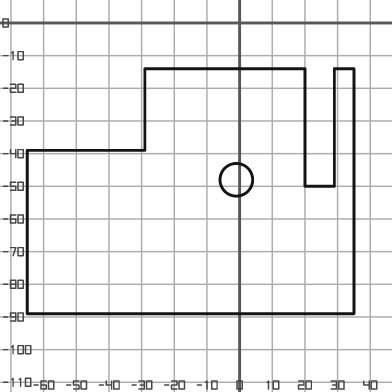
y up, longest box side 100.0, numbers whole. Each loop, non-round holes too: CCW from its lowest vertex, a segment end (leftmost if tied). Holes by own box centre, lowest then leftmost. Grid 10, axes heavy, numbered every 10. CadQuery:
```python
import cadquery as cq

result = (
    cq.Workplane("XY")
    .moveTo(-65.0, -89.0)
    .lineTo(35.0, -89.0)
    .lineTo(35.0, -14.0)
    .lineTo(29.0, -14.0)
    .lineTo(29.0, -50.0)
    .lineTo(20.0, -50.0)
    .lineTo(20.0, -14.0)
    .lineTo(-29.0, -14.0)
    .lineTo(-29.0, -39.0)
    .lineTo(-65.0, -39.0)
    .close()
    .moveTo(-1.0, -48.0)
    .circle(5.0)
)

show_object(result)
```